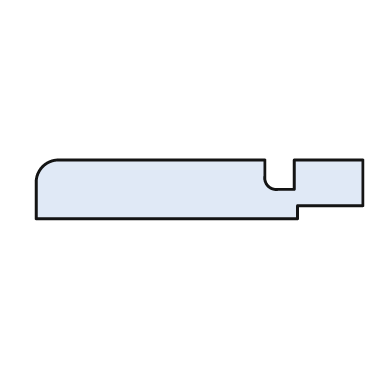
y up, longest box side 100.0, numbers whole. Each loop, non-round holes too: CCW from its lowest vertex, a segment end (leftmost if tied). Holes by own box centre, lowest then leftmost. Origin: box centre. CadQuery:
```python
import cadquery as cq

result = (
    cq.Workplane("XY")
    .moveTo(-50.0, -9.0)
    .lineTo(30.0, -9.0)
    .lineTo(30.0, -5.0)
    .lineTo(50.0, -5.0)
    .lineTo(50.0, 9.0)
    .lineTo(29.0, 9.0)
    .lineTo(29.0, 0.0)
    .lineTo(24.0, 0.0)
    .threePointArc((21.0, 1.0), (20.0, 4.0))
    .lineTo(20.0, 9.0)
    .lineTo(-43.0, 9.0)
    .threePointArc((-48.0, 7.0), (-50.0, 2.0))
    .close()
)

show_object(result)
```